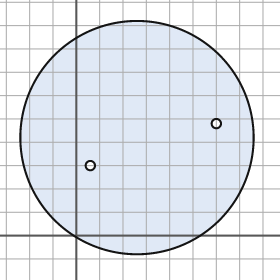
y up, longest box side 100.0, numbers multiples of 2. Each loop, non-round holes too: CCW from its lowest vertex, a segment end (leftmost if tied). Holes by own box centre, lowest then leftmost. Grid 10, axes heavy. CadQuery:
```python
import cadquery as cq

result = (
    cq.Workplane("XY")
    .moveTo(26.0, 42.0)
    .circle(50.0)
    .moveTo(6.0, 30.0)
    .circle(2.0)
    .moveTo(60.0, 48.0)
    .circle(2.0)
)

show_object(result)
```